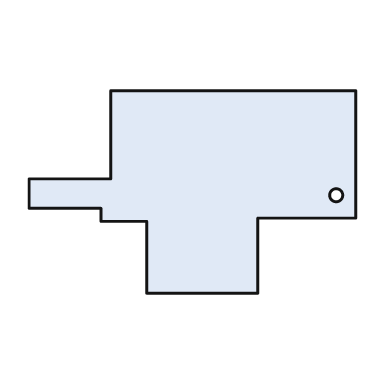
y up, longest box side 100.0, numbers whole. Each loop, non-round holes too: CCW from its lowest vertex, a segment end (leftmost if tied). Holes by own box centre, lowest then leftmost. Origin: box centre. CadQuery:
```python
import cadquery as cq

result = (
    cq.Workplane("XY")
    .moveTo(-14.0, -31.0)
    .lineTo(20.0, -31.0)
    .lineTo(20.0, -8.0)
    .lineTo(50.0, -8.0)
    .lineTo(50.0, 31.0)
    .lineTo(-25.0, 31.0)
    .lineTo(-25.0, 4.0)
    .lineTo(-50.0, 4.0)
    .lineTo(-50.0, -5.0)
    .lineTo(-28.0, -5.0)
    .lineTo(-28.0, -9.0)
    .lineTo(-14.0, -9.0)
    .close()
    .moveTo(44.0, -1.0)
    .circle(2.0)
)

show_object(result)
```